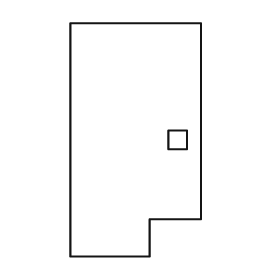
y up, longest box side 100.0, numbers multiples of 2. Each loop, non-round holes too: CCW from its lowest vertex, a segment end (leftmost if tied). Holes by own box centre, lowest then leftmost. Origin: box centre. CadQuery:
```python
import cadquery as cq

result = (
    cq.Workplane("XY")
    .moveTo(-28.0, -50.0)
    .lineTo(6.0, -50.0)
    .lineTo(6.0, -34.0)
    .lineTo(28.0, -34.0)
    .lineTo(28.0, 50.0)
    .lineTo(-28.0, 50.0)
    .close()
    .moveTo(14.0, -4.0)
    .lineTo(22.0, -4.0)
    .lineTo(22.0, 4.0)
    .lineTo(14.0, 4.0)
    .close()
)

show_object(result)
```